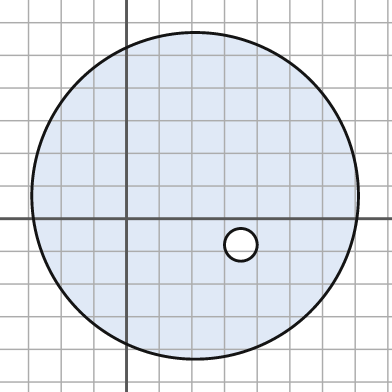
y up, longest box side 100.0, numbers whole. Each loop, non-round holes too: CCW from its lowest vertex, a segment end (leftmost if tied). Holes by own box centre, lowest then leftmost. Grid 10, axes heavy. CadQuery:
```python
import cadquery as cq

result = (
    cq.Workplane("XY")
    .moveTo(21.0, 7.0)
    .circle(50.0)
    .moveTo(35.0, -8.0)
    .circle(5.0)
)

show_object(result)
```